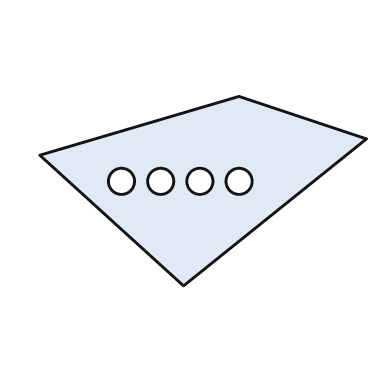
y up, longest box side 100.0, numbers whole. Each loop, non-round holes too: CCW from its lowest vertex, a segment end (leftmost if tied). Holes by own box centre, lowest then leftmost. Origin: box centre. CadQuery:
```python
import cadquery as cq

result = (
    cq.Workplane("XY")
    .moveTo(-6.0, -29.0)
    .lineTo(50.0, 16.0)
    .lineTo(11.0, 29.0)
    .lineTo(-50.0, 11.0)
    .close()
    .moveTo(-25.0, 3.0)
    .circle(4.0)
    .moveTo(-13.0, 3.0)
    .circle(4.0)
    .moveTo(-1.0, 3.0)
    .circle(4.0)
    .moveTo(11.0, 3.0)
    .circle(4.0)
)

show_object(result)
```